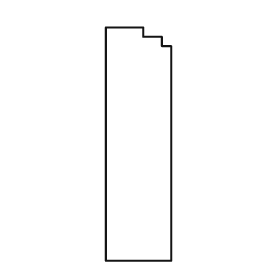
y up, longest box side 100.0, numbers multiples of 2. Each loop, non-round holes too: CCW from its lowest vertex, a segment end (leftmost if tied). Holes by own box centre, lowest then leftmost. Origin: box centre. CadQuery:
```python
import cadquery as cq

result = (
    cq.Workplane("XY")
    .moveTo(-14.0, -50.0)
    .lineTo(14.0, -50.0)
    .lineTo(14.0, 42.0)
    .lineTo(10.0, 42.0)
    .lineTo(10.0, 46.0)
    .lineTo(2.0, 46.0)
    .lineTo(2.0, 50.0)
    .lineTo(-14.0, 50.0)
    .close()
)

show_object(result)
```